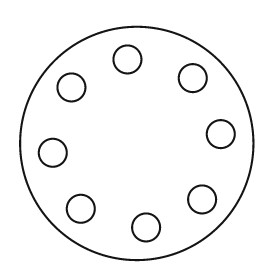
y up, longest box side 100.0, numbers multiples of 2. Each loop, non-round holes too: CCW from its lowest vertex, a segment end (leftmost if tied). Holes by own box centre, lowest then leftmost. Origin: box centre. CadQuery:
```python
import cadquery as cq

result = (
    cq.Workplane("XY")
    .moveTo(0.0, 0.0)
    .circle(50.0)
    .moveTo(4.0, -36.0)
    .circle(6.0)
    .moveTo(-24.0, -28.0)
    .circle(6.0)
    .moveTo(28.0, -24.0)
    .circle(6.0)
    .moveTo(-36.0, -4.0)
    .circle(6.0)
    .moveTo(36.0, 4.0)
    .circle(6.0)
    .moveTo(-28.0, 24.0)
    .circle(6.0)
    .moveTo(24.0, 28.0)
    .circle(6.0)
    .moveTo(-4.0, 36.0)
    .circle(6.0)
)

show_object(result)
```